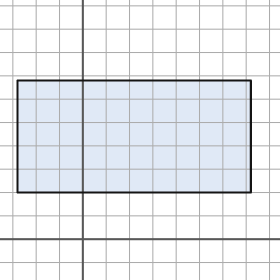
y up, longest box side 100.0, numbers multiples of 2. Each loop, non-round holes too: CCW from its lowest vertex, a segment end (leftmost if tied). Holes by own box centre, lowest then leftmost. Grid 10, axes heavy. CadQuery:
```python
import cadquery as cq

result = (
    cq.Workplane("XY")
    .moveTo(-28.0, 20.0)
    .lineTo(72.0, 20.0)
    .lineTo(72.0, 68.0)
    .lineTo(-28.0, 68.0)
    .close()
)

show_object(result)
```